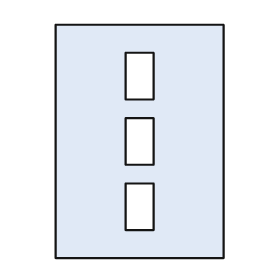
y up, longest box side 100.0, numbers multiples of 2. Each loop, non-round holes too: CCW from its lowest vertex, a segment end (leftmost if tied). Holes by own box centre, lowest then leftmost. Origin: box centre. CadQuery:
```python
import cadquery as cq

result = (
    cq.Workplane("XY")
    .moveTo(-36.0, -50.0)
    .lineTo(36.0, -50.0)
    .lineTo(36.0, 50.0)
    .lineTo(-36.0, 50.0)
    .close()
    .moveTo(-6.0, -38.0)
    .lineTo(6.0, -38.0)
    .lineTo(6.0, -18.0)
    .lineTo(-6.0, -18.0)
    .close()
    .moveTo(-6.0, -10.0)
    .lineTo(6.0, -10.0)
    .lineTo(6.0, 10.0)
    .lineTo(-6.0, 10.0)
    .close()
    .moveTo(-6.0, 18.0)
    .lineTo(6.0, 18.0)
    .lineTo(6.0, 38.0)
    .lineTo(-6.0, 38.0)
    .close()
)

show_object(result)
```